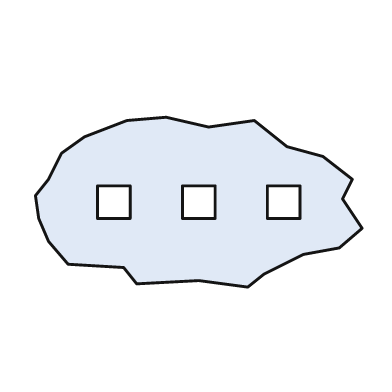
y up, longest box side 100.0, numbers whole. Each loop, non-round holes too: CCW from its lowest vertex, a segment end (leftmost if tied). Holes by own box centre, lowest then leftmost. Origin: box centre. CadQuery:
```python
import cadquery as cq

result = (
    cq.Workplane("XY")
    .moveTo(15.0, -26.0)
    .lineTo(20.0, -22.0)
    .lineTo(32.0, -16.0)
    .lineTo(43.0, -14.0)
    .lineTo(50.0, -8.0)
    .lineTo(44.0, 1.0)
    .lineTo(47.0, 7.0)
    .lineTo(38.0, 14.0)
    .lineTo(27.0, 17.0)
    .lineTo(17.0, 25.0)
    .lineTo(3.0, 23.0)
    .lineTo(-10.0, 26.0)
    .lineTo(-22.0, 25.0)
    .lineTo(-35.0, 20.0)
    .lineTo(-42.0, 15.0)
    .lineTo(-46.0, 7.0)
    .lineTo(-50.0, 2.0)
    .lineTo(-49.0, -5.0)
    .lineTo(-46.0, -12.0)
    .lineTo(-40.0, -19.0)
    .lineTo(-23.0, -20.0)
    .lineTo(-19.0, -25.0)
    .lineTo(0.0, -24.0)
    .close()
    .moveTo(-31.0, -5.0)
    .lineTo(-21.0, -5.0)
    .lineTo(-21.0, 5.0)
    .lineTo(-31.0, 5.0)
    .close()
    .moveTo(-5.0, -5.0)
    .lineTo(5.0, -5.0)
    .lineTo(5.0, 5.0)
    .lineTo(-5.0, 5.0)
    .close()
    .moveTo(21.0, -5.0)
    .lineTo(31.0, -5.0)
    .lineTo(31.0, 5.0)
    .lineTo(21.0, 5.0)
    .close()
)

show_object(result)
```